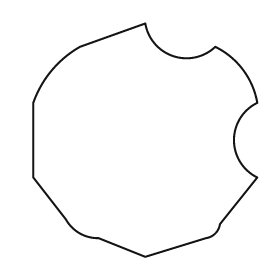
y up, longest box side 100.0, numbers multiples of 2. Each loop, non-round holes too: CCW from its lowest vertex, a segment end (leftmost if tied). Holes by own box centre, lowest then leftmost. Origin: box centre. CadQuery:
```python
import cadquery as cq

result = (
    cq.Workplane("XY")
    .moveTo(0.0, -50.0)
    .lineTo(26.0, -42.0)
    .threePointArc((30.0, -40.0), (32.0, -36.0))
    .lineTo(48.0, -16.0)
    .threePointArc((38.0, 0.0), (48.0, 16.0))
    .threePointArc((42.0, 30.0), (30.0, 40.0))
    .threePointArc((12.0, 36.0), (0.0, 50.0))
    .lineTo(-28.0, 40.0)
    .threePointArc((-40.0, 30.0), (-48.0, 16.0))
    .lineTo(-48.0, -16.0)
    .lineTo(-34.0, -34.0)
    .threePointArc((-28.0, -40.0), (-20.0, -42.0))
    .close()
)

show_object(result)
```